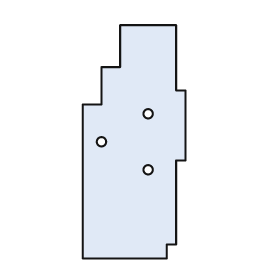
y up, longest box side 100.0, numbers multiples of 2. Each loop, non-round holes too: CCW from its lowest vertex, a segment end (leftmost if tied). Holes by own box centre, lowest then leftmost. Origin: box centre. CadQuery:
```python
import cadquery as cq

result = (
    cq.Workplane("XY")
    .moveTo(-22.0, -50.0)
    .lineTo(14.0, -50.0)
    .lineTo(14.0, -44.0)
    .lineTo(18.0, -44.0)
    .lineTo(18.0, -8.0)
    .lineTo(22.0, -8.0)
    .lineTo(22.0, 22.0)
    .lineTo(18.0, 22.0)
    .lineTo(18.0, 50.0)
    .lineTo(-6.0, 50.0)
    .lineTo(-6.0, 32.0)
    .lineTo(-14.0, 32.0)
    .lineTo(-14.0, 16.0)
    .lineTo(-22.0, 16.0)
    .close()
    .moveTo(6.0, -12.0)
    .circle(2.0)
    .moveTo(-14.0, 0.0)
    .circle(2.0)
    .moveTo(6.0, 12.0)
    .circle(2.0)
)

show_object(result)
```